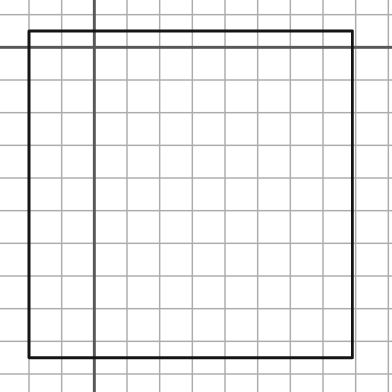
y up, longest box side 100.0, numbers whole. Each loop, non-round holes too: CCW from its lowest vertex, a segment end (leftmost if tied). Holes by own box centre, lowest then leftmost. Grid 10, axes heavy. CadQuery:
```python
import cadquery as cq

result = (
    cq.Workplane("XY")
    .moveTo(-20.0, -95.0)
    .lineTo(79.0, -95.0)
    .lineTo(79.0, 5.0)
    .lineTo(-20.0, 5.0)
    .close()
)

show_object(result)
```